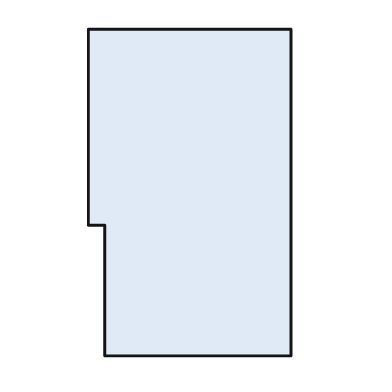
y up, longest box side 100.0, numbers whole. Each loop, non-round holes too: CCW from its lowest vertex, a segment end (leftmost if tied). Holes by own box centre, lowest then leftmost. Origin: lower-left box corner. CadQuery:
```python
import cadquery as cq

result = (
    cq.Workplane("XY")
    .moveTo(5.0, 0.0)
    .lineTo(62.0, 0.0)
    .lineTo(62.0, 100.0)
    .lineTo(0.0, 100.0)
    .lineTo(0.0, 40.0)
    .lineTo(5.0, 40.0)
    .close()
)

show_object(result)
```